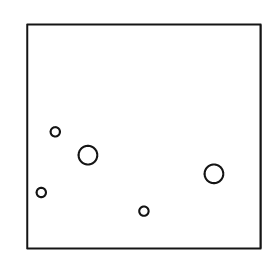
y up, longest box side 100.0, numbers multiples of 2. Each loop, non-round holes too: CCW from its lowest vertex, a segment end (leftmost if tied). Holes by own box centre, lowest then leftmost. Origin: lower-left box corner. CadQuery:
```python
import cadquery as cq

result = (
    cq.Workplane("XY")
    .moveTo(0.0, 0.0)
    .lineTo(100.0, 0.0)
    .lineTo(100.0, 96.0)
    .lineTo(0.0, 96.0)
    .close()
    .moveTo(50.0, 16.0)
    .circle(2.0)
    .moveTo(6.0, 24.0)
    .circle(2.0)
    .moveTo(80.0, 32.0)
    .circle(4.0)
    .moveTo(26.0, 40.0)
    .circle(4.0)
    .moveTo(12.0, 50.0)
    .circle(2.0)
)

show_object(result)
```